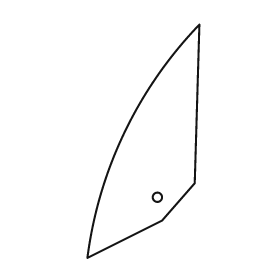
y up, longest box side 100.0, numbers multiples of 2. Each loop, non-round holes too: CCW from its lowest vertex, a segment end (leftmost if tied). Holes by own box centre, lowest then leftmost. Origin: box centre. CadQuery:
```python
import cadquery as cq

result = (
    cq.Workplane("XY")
    .moveTo(-24.0, -50.0)
    .lineTo(8.0, -34.0)
    .lineTo(22.0, -18.0)
    .lineTo(24.0, 50.0)
    .threePointArc((-8.0, 4.0), (-24.0, -50.0))
    .close()
    .moveTo(6.0, -24.0)
    .circle(2.0)
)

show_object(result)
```